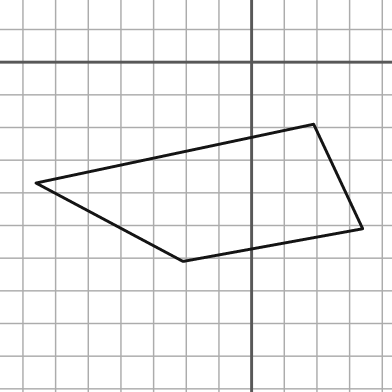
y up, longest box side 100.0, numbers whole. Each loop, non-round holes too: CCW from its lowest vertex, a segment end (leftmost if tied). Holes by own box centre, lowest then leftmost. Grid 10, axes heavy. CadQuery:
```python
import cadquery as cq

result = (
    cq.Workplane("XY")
    .moveTo(-21.0, -61.0)
    .lineTo(34.0, -51.0)
    .lineTo(19.0, -19.0)
    .lineTo(-66.0, -37.0)
    .close()
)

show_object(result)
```